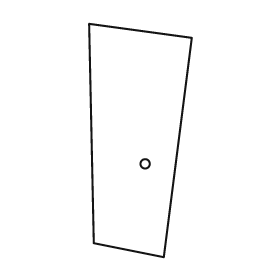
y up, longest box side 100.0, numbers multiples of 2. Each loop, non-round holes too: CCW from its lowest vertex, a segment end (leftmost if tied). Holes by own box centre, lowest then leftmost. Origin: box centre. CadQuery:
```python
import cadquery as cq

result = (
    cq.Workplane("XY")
    .moveTo(10.0, -50.0)
    .lineTo(22.0, 44.0)
    .lineTo(-22.0, 50.0)
    .lineTo(-20.0, -44.0)
    .close()
    .moveTo(2.0, -10.0)
    .circle(2.0)
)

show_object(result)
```